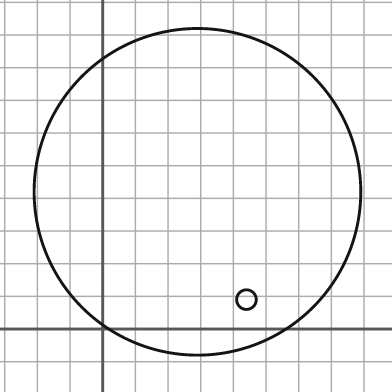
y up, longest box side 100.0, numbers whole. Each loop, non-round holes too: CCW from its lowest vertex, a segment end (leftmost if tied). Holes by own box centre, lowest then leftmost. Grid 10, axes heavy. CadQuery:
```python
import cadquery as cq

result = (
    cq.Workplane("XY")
    .moveTo(29.0, 42.0)
    .circle(50.0)
    .moveTo(44.0, 9.0)
    .circle(3.0)
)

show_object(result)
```